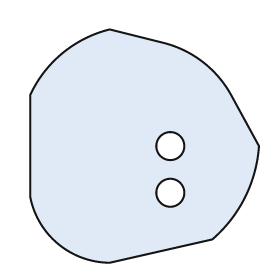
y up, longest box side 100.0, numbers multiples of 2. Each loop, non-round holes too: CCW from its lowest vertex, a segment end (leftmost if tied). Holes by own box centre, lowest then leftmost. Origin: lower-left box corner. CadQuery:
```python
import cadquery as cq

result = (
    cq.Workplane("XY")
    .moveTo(34.0, 0.0)
    .lineTo(78.0, 10.0)
    .threePointArc((92.0, 28.0), (98.0, 50.0))
    .lineTo(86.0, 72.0)
    .threePointArc((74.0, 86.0), (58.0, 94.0))
    .lineTo(34.0, 100.0)
    .threePointArc((14.0, 90.0), (0.0, 72.0))
    .lineTo(0.0, 28.0)
    .threePointArc((12.0, 8.0), (34.0, 0.0))
    .close()
    .moveTo(60.0, 30.0)
    .circle(6.0)
    .moveTo(60.0, 50.0)
    .circle(6.0)
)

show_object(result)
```